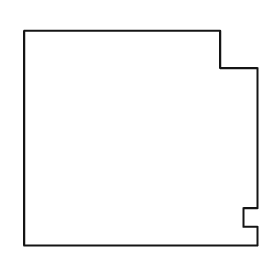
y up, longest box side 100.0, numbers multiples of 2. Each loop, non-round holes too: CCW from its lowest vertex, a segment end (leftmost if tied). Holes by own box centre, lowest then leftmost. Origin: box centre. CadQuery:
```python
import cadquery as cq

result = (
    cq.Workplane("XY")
    .moveTo(-50.0, -46.0)
    .lineTo(50.0, -46.0)
    .lineTo(50.0, -38.0)
    .lineTo(44.0, -38.0)
    .lineTo(44.0, -30.0)
    .lineTo(50.0, -30.0)
    .lineTo(50.0, 30.0)
    .lineTo(34.0, 30.0)
    .lineTo(34.0, 46.0)
    .lineTo(-50.0, 46.0)
    .close()
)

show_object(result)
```